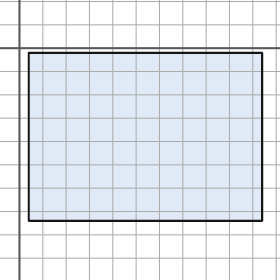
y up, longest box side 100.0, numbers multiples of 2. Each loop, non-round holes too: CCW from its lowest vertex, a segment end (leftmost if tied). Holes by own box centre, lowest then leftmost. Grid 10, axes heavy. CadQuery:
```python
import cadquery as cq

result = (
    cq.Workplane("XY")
    .moveTo(4.0, -74.0)
    .lineTo(104.0, -74.0)
    .lineTo(104.0, -2.0)
    .lineTo(4.0, -2.0)
    .close()
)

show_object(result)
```